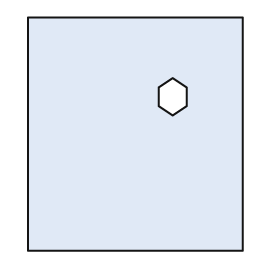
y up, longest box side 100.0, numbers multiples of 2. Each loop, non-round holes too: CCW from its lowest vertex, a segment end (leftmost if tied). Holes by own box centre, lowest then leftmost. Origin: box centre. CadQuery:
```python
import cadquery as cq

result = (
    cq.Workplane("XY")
    .moveTo(-46.0, -50.0)
    .lineTo(46.0, -50.0)
    .lineTo(46.0, 50.0)
    .lineTo(-46.0, 50.0)
    .close()
    .moveTo(16.0, 8.0)
    .lineTo(22.0, 12.0)
    .lineTo(22.0, 20.0)
    .lineTo(16.0, 24.0)
    .lineTo(10.0, 20.0)
    .lineTo(10.0, 12.0)
    .close()
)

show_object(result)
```